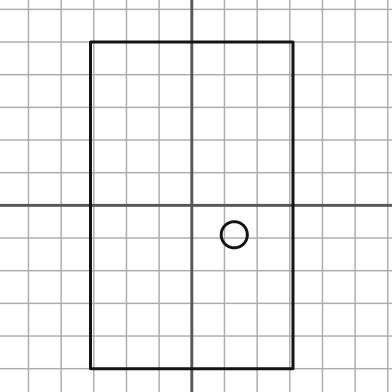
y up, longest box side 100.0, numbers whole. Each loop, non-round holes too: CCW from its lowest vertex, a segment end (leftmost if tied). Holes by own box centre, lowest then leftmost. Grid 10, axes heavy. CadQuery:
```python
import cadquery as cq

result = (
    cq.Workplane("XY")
    .moveTo(-31.0, -50.0)
    .lineTo(31.0, -50.0)
    .lineTo(31.0, 50.0)
    .lineTo(-31.0, 50.0)
    .close()
    .moveTo(13.0, -9.0)
    .circle(4.0)
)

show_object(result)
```